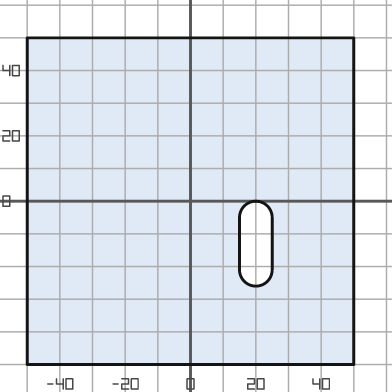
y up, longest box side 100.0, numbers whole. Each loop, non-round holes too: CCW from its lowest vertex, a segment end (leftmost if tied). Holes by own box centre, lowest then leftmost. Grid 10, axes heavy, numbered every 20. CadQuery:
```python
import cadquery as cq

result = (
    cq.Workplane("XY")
    .moveTo(-50.0, -50.0)
    .lineTo(50.0, -50.0)
    .lineTo(50.0, 50.0)
    .lineTo(-50.0, 50.0)
    .close()
    .moveTo(15.0, -21.0)
    .threePointArc((20.0, -26.0), (25.0, -21.0))
    .lineTo(25.0, -5.0)
    .threePointArc((20.0, 0.0), (15.0, -5.0))
    .close()
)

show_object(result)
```